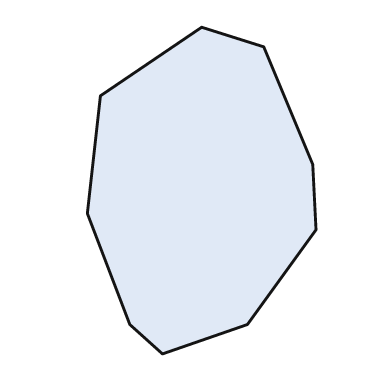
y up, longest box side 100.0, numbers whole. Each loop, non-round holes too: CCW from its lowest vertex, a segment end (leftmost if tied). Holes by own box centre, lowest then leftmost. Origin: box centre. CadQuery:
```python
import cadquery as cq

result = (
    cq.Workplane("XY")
    .moveTo(-12.0, -50.0)
    .lineTo(14.0, -41.0)
    .lineTo(35.0, -12.0)
    .lineTo(34.0, 8.0)
    .lineTo(19.0, 44.0)
    .lineTo(0.0, 50.0)
    .lineTo(-31.0, 29.0)
    .lineTo(-35.0, -7.0)
    .lineTo(-22.0, -41.0)
    .close()
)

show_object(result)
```